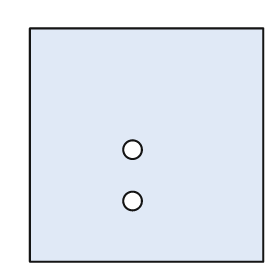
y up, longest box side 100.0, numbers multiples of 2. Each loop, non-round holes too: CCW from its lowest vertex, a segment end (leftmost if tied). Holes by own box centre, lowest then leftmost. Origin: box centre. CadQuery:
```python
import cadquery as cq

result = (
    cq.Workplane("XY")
    .moveTo(-50.0, -50.0)
    .lineTo(50.0, -50.0)
    .lineTo(50.0, 50.0)
    .lineTo(-50.0, 50.0)
    .close()
    .moveTo(-6.0, -24.0)
    .circle(4.0)
    .moveTo(-6.0, -2.0)
    .circle(4.0)
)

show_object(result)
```